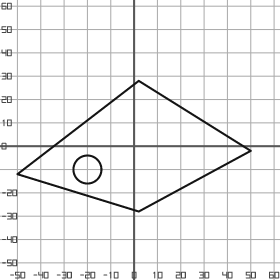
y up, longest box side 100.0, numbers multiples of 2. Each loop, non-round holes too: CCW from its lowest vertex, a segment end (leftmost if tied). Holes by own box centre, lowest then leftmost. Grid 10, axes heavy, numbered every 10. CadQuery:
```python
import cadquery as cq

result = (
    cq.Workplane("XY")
    .moveTo(2.0, -28.0)
    .lineTo(50.0, -2.0)
    .lineTo(2.0, 28.0)
    .lineTo(-50.0, -12.0)
    .close()
    .moveTo(-20.0, -10.0)
    .circle(6.0)
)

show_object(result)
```